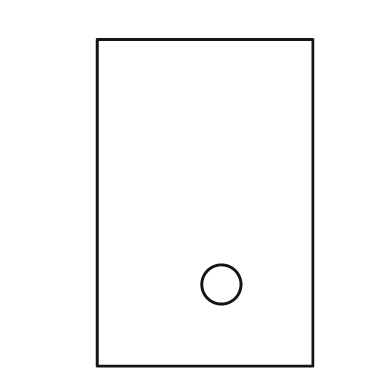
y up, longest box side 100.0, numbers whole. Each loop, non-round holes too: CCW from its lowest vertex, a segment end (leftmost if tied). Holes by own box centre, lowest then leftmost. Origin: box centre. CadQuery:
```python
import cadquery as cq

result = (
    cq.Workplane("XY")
    .moveTo(-33.0, -50.0)
    .lineTo(33.0, -50.0)
    .lineTo(33.0, 50.0)
    .lineTo(-33.0, 50.0)
    .close()
    .moveTo(5.0, -25.0)
    .circle(6.0)
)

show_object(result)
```